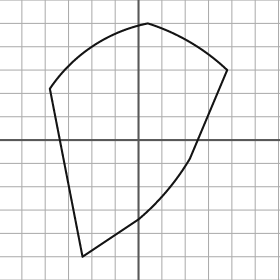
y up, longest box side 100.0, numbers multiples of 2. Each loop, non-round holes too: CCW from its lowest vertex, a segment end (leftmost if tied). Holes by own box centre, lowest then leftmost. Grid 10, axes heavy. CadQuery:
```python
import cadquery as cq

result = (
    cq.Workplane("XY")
    .moveTo(-24.0, -50.0)
    .lineTo(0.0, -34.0)
    .threePointArc((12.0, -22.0), (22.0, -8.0))
    .lineTo(38.0, 30.0)
    .threePointArc((22.0, 42.0), (4.0, 50.0))
    .threePointArc((-20.0, 40.0), (-38.0, 22.0))
    .close()
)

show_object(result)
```